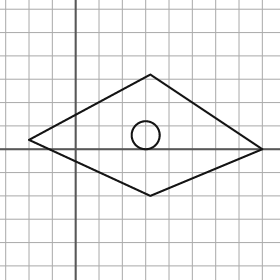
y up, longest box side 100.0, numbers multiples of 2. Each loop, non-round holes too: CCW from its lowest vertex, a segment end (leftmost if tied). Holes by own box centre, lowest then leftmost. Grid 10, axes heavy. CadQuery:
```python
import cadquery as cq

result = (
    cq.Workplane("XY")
    .moveTo(32.0, -20.0)
    .lineTo(80.0, 0.0)
    .lineTo(32.0, 32.0)
    .lineTo(-20.0, 4.0)
    .close()
    .moveTo(30.0, 6.0)
    .circle(6.0)
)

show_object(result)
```